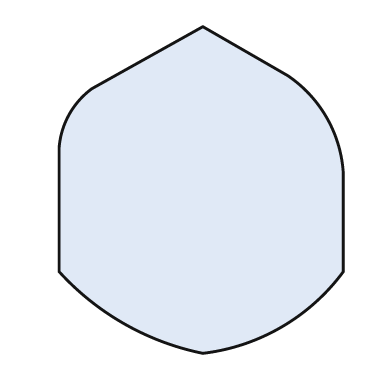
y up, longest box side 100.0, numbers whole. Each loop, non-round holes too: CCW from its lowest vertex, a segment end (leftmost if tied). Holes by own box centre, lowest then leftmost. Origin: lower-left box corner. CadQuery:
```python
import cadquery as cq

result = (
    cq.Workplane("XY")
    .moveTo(44.0, 0.0)
    .threePointArc((68.0, 8.0), (87.0, 25.0))
    .lineTo(87.0, 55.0)
    .threePointArc((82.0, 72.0), (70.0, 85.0))
    .lineTo(44.0, 100.0)
    .lineTo(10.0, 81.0)
    .threePointArc((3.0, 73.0), (0.0, 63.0))
    .lineTo(0.0, 25.0)
    .threePointArc((20.0, 9.0), (44.0, 0.0))
    .close()
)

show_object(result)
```